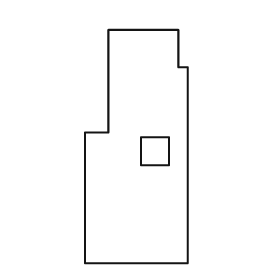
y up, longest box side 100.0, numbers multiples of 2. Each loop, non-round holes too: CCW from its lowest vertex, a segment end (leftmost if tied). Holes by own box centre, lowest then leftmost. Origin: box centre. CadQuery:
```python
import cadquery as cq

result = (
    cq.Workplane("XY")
    .moveTo(-22.0, -50.0)
    .lineTo(22.0, -50.0)
    .lineTo(22.0, 34.0)
    .lineTo(18.0, 34.0)
    .lineTo(18.0, 50.0)
    .lineTo(-12.0, 50.0)
    .lineTo(-12.0, 6.0)
    .lineTo(-22.0, 6.0)
    .close()
    .moveTo(2.0, -8.0)
    .lineTo(14.0, -8.0)
    .lineTo(14.0, 4.0)
    .lineTo(2.0, 4.0)
    .close()
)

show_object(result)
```